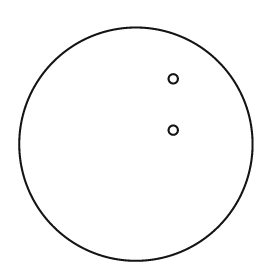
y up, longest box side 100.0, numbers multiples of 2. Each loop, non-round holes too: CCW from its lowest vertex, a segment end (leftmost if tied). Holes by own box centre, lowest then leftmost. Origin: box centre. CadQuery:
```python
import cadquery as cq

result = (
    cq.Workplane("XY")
    .moveTo(0.0, 0.0)
    .circle(50.0)
    .moveTo(16.0, 6.0)
    .circle(2.0)
    .moveTo(16.0, 28.0)
    .circle(2.0)
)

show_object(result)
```